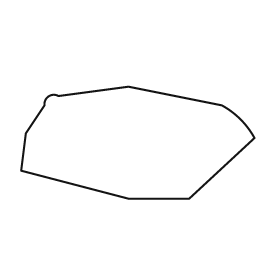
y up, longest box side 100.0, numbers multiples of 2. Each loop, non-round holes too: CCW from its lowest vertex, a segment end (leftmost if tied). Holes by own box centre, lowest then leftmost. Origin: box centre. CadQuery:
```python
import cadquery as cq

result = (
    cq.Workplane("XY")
    .moveTo(-4.0, -24.0)
    .lineTo(22.0, -24.0)
    .lineTo(50.0, 2.0)
    .threePointArc((44.0, 10.0), (36.0, 16.0))
    .lineTo(-4.0, 24.0)
    .lineTo(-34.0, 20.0)
    .threePointArc((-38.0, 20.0), (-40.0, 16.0))
    .lineTo(-48.0, 4.0)
    .lineTo(-50.0, -12.0)
    .close()
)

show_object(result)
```